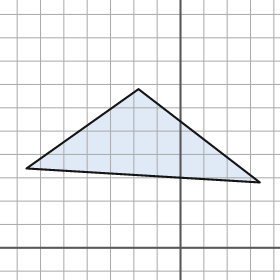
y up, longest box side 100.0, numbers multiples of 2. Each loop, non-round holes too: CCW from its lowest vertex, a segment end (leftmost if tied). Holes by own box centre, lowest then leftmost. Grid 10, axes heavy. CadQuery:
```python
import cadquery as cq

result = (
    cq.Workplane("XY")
    .moveTo(34.0, 28.0)
    .lineTo(-18.0, 68.0)
    .lineTo(-66.0, 34.0)
    .close()
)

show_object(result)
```